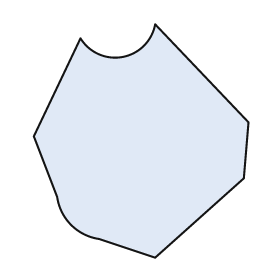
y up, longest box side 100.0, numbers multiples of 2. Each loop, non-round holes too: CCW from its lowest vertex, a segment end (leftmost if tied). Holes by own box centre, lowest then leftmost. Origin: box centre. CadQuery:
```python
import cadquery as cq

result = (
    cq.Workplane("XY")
    .moveTo(6.0, -50.0)
    .lineTo(44.0, -16.0)
    .lineTo(46.0, 8.0)
    .lineTo(6.0, 50.0)
    .threePointArc((-8.0, 36.0), (-26.0, 44.0))
    .lineTo(-46.0, 2.0)
    .lineTo(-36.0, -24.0)
    .threePointArc((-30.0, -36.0), (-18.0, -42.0))
    .close()
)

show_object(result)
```